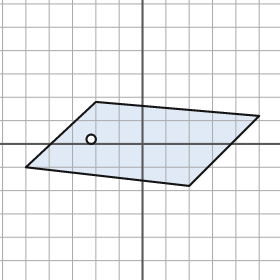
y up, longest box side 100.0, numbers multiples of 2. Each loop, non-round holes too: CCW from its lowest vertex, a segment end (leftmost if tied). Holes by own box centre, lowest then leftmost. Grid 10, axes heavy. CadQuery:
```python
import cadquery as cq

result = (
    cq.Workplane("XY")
    .moveTo(20.0, -18.0)
    .lineTo(50.0, 12.0)
    .lineTo(-20.0, 18.0)
    .lineTo(-50.0, -10.0)
    .close()
    .moveTo(-22.0, 2.0)
    .circle(2.0)
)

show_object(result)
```